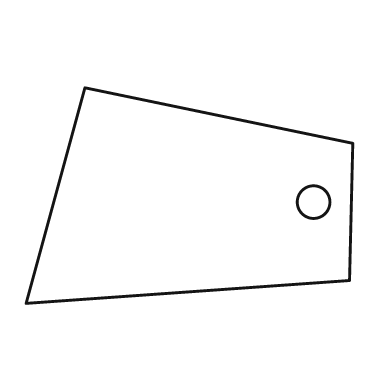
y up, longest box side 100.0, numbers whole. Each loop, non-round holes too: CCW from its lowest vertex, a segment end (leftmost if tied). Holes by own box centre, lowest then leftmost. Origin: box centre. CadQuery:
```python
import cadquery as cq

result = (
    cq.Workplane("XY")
    .moveTo(-50.0, -33.0)
    .lineTo(49.0, -26.0)
    .lineTo(50.0, 16.0)
    .lineTo(-32.0, 33.0)
    .close()
    .moveTo(38.0, -2.0)
    .circle(5.0)
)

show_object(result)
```